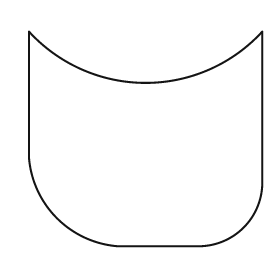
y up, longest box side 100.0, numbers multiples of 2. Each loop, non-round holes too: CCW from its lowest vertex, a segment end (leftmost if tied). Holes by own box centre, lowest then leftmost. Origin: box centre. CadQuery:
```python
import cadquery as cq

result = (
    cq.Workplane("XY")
    .moveTo(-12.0, -46.0)
    .lineTo(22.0, -46.0)
    .threePointArc((42.0, -38.0), (50.0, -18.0))
    .lineTo(50.0, 46.0)
    .threePointArc((0.0, 24.0), (-50.0, 46.0))
    .lineTo(-50.0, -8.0)
    .threePointArc((-38.0, -34.0), (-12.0, -46.0))
    .close()
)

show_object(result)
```